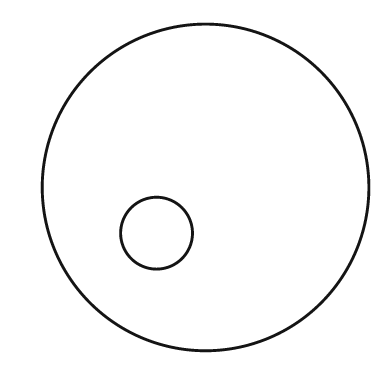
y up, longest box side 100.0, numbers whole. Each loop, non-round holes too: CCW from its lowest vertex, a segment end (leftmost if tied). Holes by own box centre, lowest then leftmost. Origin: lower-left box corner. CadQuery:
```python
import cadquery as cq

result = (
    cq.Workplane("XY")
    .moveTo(50.0, 50.0)
    .circle(50.0)
    .moveTo(35.0, 36.0)
    .circle(11.0)
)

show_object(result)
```